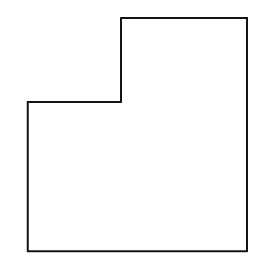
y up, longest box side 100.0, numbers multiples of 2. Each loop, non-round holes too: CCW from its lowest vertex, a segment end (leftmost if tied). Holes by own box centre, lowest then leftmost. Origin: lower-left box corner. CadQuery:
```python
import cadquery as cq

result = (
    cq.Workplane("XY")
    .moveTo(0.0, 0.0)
    .lineTo(94.0, 0.0)
    .lineTo(94.0, 100.0)
    .lineTo(40.0, 100.0)
    .lineTo(40.0, 64.0)
    .lineTo(0.0, 64.0)
    .close()
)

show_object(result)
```